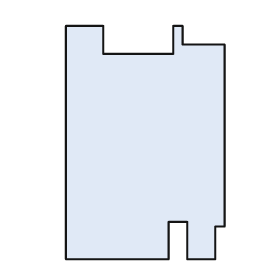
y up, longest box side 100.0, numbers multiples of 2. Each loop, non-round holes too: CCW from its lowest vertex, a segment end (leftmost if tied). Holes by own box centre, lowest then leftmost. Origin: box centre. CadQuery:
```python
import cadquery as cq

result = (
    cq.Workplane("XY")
    .moveTo(-34.0, -50.0)
    .lineTo(10.0, -50.0)
    .lineTo(10.0, -34.0)
    .lineTo(18.0, -34.0)
    .lineTo(18.0, -50.0)
    .lineTo(30.0, -50.0)
    .lineTo(30.0, -36.0)
    .lineTo(34.0, -36.0)
    .lineTo(34.0, 42.0)
    .lineTo(16.0, 42.0)
    .lineTo(16.0, 50.0)
    .lineTo(12.0, 50.0)
    .lineTo(12.0, 38.0)
    .lineTo(-18.0, 38.0)
    .lineTo(-18.0, 50.0)
    .lineTo(-34.0, 50.0)
    .close()
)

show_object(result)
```